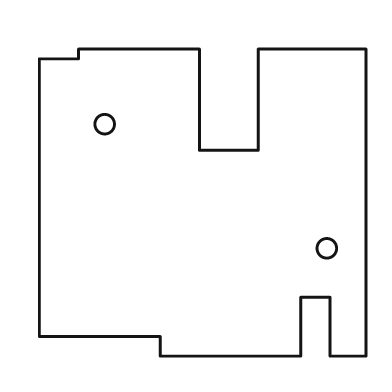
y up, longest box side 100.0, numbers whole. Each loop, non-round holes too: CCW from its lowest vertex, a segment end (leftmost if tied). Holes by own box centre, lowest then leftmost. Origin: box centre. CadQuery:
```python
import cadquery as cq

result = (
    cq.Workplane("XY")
    .moveTo(-13.0, -47.0)
    .lineTo(30.0, -47.0)
    .lineTo(30.0, -29.0)
    .lineTo(39.0, -29.0)
    .lineTo(39.0, -47.0)
    .lineTo(50.0, -47.0)
    .lineTo(50.0, 47.0)
    .lineTo(17.0, 47.0)
    .lineTo(17.0, 16.0)
    .lineTo(-1.0, 16.0)
    .lineTo(-1.0, 47.0)
    .lineTo(-38.0, 47.0)
    .lineTo(-38.0, 44.0)
    .lineTo(-50.0, 44.0)
    .lineTo(-50.0, -41.0)
    .lineTo(-13.0, -41.0)
    .close()
    .moveTo(38.0, -14.0)
    .circle(3.0)
    .moveTo(-30.0, 24.0)
    .circle(3.0)
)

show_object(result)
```